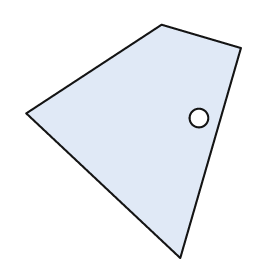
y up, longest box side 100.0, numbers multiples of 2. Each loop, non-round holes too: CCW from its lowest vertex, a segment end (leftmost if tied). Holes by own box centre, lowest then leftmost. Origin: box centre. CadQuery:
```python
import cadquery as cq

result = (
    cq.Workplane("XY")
    .moveTo(20.0, -50.0)
    .lineTo(46.0, 40.0)
    .lineTo(12.0, 50.0)
    .lineTo(-46.0, 12.0)
    .close()
    .moveTo(28.0, 10.0)
    .circle(4.0)
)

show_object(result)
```